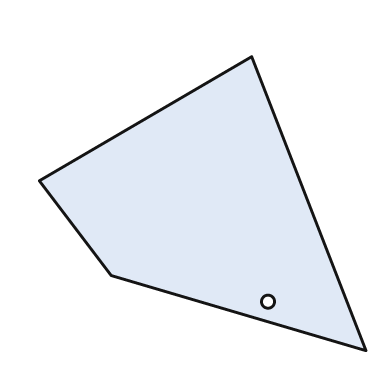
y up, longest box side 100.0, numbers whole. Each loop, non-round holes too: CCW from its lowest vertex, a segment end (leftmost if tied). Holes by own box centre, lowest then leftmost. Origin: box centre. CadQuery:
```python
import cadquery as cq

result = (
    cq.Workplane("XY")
    .moveTo(50.0, -45.0)
    .lineTo(15.0, 45.0)
    .lineTo(-50.0, 7.0)
    .lineTo(-28.0, -22.0)
    .close()
    .moveTo(20.0, -30.0)
    .circle(2.0)
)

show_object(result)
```